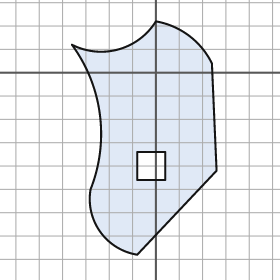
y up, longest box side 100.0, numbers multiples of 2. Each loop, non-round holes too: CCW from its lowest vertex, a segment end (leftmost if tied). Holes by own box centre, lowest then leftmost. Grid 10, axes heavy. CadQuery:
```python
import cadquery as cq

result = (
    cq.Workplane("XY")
    .moveTo(-8.0, -78.0)
    .lineTo(26.0, -42.0)
    .lineTo(24.0, 4.0)
    .threePointArc((14.0, 16.0), (0.0, 22.0))
    .threePointArc((-16.0, 10.0), (-36.0, 12.0))
    .threePointArc((-24.0, -18.0), (-28.0, -50.0))
    .threePointArc((-24.0, -68.0), (-8.0, -78.0))
    .close()
    .moveTo(-8.0, -46.0)
    .lineTo(4.0, -46.0)
    .lineTo(4.0, -34.0)
    .lineTo(-8.0, -34.0)
    .close()
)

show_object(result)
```